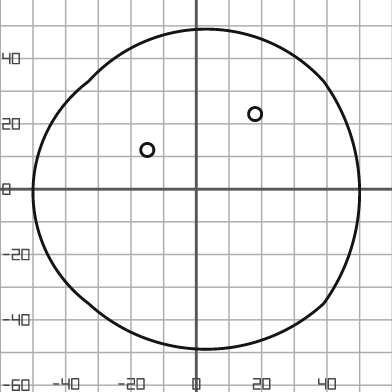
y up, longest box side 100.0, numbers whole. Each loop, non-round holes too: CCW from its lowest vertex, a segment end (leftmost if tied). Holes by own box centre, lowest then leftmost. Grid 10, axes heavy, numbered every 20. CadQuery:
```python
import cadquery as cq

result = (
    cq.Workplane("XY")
    .moveTo(-33.0, -35.0)
    .threePointArc((3.0, -49.0), (39.0, -35.0))
    .threePointArc((50.0, -1.0), (39.0, 33.0))
    .threePointArc((3.0, 49.0), (-33.0, 33.0))
    .threePointArc((-50.0, -1.0), (-33.0, -35.0))
    .close()
    .moveTo(-15.0, 12.0)
    .circle(2.0)
    .moveTo(18.0, 23.0)
    .circle(2.0)
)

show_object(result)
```